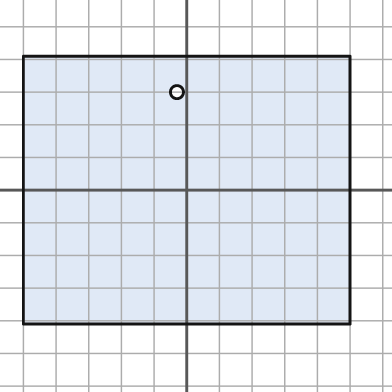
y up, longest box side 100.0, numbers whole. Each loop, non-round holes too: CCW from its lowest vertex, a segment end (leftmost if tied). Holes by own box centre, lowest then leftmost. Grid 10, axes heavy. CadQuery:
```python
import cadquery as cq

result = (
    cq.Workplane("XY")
    .moveTo(-50.0, -41.0)
    .lineTo(50.0, -41.0)
    .lineTo(50.0, 41.0)
    .lineTo(-50.0, 41.0)
    .close()
    .moveTo(-3.0, 30.0)
    .circle(2.0)
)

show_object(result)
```